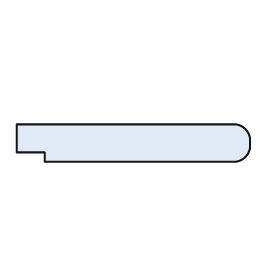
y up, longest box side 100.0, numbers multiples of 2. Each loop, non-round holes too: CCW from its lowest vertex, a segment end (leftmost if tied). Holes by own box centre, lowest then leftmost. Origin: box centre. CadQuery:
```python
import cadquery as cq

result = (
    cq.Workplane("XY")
    .moveTo(-38.0, -8.0)
    .lineTo(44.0, -8.0)
    .threePointArc((48.0, -6.0), (50.0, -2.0))
    .lineTo(50.0, 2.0)
    .threePointArc((48.0, 6.0), (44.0, 8.0))
    .lineTo(-50.0, 8.0)
    .lineTo(-50.0, -4.0)
    .lineTo(-38.0, -4.0)
    .close()
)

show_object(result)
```